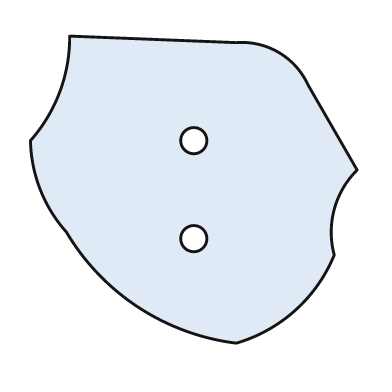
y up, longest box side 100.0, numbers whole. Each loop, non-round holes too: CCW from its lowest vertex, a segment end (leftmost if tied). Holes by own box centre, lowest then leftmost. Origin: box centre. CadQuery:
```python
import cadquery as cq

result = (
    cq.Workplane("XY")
    .moveTo(13.0, -47.0)
    .threePointArc((31.0, -37.0), (43.0, -20.0))
    .threePointArc((43.0, -6.0), (50.0, 6.0))
    .lineTo(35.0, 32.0)
    .threePointArc((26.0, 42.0), (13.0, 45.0))
    .lineTo(-38.0, 47.0)
    .threePointArc((-41.0, 30.0), (-50.0, 15.0))
    .threePointArc((-47.0, 0.0), (-39.0, -13.0))
    .threePointArc((-17.0, -36.0), (13.0, -47.0))
    .close()
    .moveTo(0.0, -15.0)
    .circle(4.0)
    .moveTo(0.0, 15.0)
    .circle(4.0)
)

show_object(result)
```